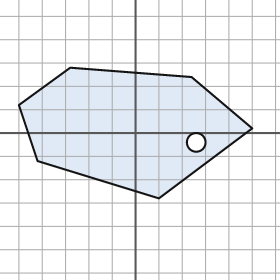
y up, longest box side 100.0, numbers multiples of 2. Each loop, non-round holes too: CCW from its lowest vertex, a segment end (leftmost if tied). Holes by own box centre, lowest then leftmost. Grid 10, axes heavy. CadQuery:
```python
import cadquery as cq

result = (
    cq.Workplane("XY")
    .moveTo(10.0, -28.0)
    .lineTo(50.0, 2.0)
    .lineTo(24.0, 24.0)
    .lineTo(-28.0, 28.0)
    .lineTo(-50.0, 12.0)
    .lineTo(-42.0, -12.0)
    .close()
    .moveTo(26.0, -4.0)
    .circle(4.0)
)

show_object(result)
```